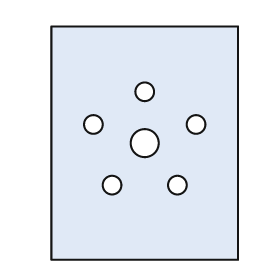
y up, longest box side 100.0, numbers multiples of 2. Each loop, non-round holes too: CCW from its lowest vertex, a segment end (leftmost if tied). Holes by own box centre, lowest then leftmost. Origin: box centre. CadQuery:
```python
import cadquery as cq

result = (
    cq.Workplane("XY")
    .moveTo(-40.0, -50.0)
    .lineTo(40.0, -50.0)
    .lineTo(40.0, 50.0)
    .lineTo(-40.0, 50.0)
    .close()
    .moveTo(-14.0, -18.0)
    .circle(4.0)
    .moveTo(14.0, -18.0)
    .circle(4.0)
    .moveTo(0.0, 0.0)
    .circle(6.0)
    .moveTo(-22.0, 8.0)
    .circle(4.0)
    .moveTo(22.0, 8.0)
    .circle(4.0)
    .moveTo(0.0, 22.0)
    .circle(4.0)
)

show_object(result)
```